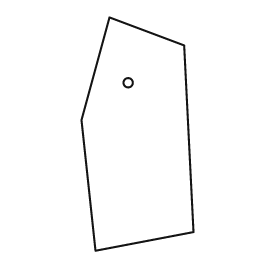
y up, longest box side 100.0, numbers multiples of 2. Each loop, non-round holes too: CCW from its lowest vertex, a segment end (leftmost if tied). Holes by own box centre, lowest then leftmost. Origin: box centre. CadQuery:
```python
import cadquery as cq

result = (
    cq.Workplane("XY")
    .moveTo(-18.0, -50.0)
    .lineTo(24.0, -42.0)
    .lineTo(20.0, 38.0)
    .lineTo(-12.0, 50.0)
    .lineTo(-24.0, 6.0)
    .close()
    .moveTo(-4.0, 22.0)
    .circle(2.0)
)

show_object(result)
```